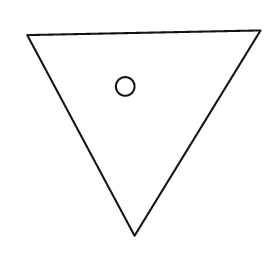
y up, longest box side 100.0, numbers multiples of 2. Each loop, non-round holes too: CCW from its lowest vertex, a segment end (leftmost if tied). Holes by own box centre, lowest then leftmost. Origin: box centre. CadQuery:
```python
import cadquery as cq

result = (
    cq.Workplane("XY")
    .moveTo(-4.0, -44.0)
    .lineTo(50.0, 44.0)
    .lineTo(-50.0, 42.0)
    .close()
    .moveTo(-8.0, 20.0)
    .circle(4.0)
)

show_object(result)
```